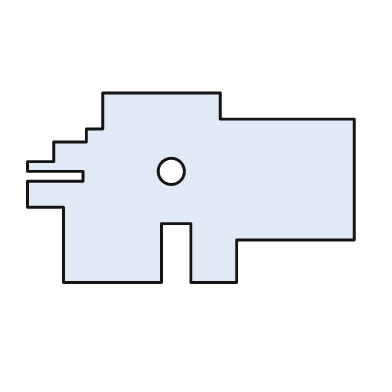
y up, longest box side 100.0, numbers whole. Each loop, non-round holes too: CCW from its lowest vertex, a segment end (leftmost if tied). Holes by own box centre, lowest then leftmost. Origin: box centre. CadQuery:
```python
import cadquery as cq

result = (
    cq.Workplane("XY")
    .moveTo(-39.0, -29.0)
    .lineTo(-9.0, -29.0)
    .lineTo(-9.0, -11.0)
    .lineTo(0.0, -11.0)
    .lineTo(0.0, -29.0)
    .lineTo(14.0, -29.0)
    .lineTo(14.0, -16.0)
    .lineTo(50.0, -16.0)
    .lineTo(50.0, 21.0)
    .lineTo(9.0, 21.0)
    .lineTo(9.0, 29.0)
    .lineTo(-27.0, 29.0)
    .lineTo(-27.0, 18.0)
    .lineTo(-32.0, 18.0)
    .lineTo(-32.0, 14.0)
    .lineTo(-42.0, 14.0)
    .lineTo(-42.0, 8.0)
    .lineTo(-50.0, 8.0)
    .lineTo(-50.0, 5.0)
    .lineTo(-33.0, 5.0)
    .lineTo(-33.0, 2.0)
    .lineTo(-50.0, 2.0)
    .lineTo(-50.0, -6.0)
    .lineTo(-39.0, -6.0)
    .close()
    .moveTo(-6.0, 5.0)
    .circle(4.0)
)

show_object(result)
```